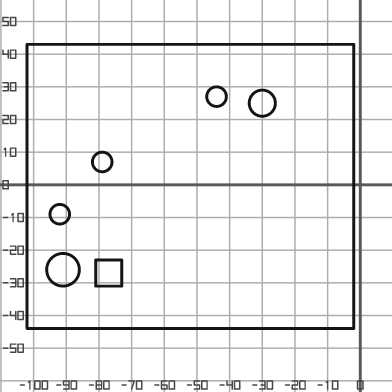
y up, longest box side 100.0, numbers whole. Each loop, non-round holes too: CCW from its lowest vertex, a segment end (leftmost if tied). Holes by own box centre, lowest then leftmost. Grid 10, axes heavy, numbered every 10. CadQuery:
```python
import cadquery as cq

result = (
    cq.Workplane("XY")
    .moveTo(-102.0, -44.0)
    .lineTo(-2.0, -44.0)
    .lineTo(-2.0, 43.0)
    .lineTo(-102.0, 43.0)
    .close()
    .moveTo(-81.0, -31.0)
    .lineTo(-73.0, -31.0)
    .lineTo(-73.0, -23.0)
    .lineTo(-81.0, -23.0)
    .close()
    .moveTo(-91.0, -26.0)
    .circle(5.0)
    .moveTo(-92.0, -9.0)
    .circle(3.0)
    .moveTo(-79.0, 7.0)
    .circle(3.0)
    .moveTo(-30.0, 25.0)
    .circle(4.0)
    .moveTo(-44.0, 27.0)
    .circle(3.0)
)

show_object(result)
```